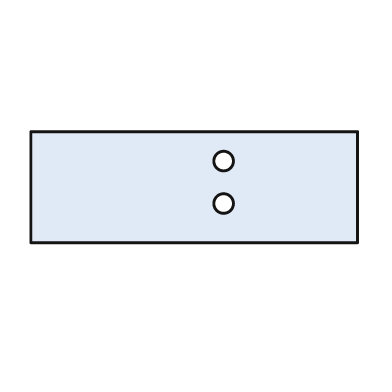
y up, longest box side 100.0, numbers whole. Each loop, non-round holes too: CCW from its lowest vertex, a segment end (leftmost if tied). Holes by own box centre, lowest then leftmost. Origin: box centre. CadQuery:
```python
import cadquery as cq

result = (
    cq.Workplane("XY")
    .moveTo(-50.0, -17.0)
    .lineTo(50.0, -17.0)
    .lineTo(50.0, 17.0)
    .lineTo(-50.0, 17.0)
    .close()
    .moveTo(9.0, -5.0)
    .circle(3.0)
    .moveTo(9.0, 8.0)
    .circle(3.0)
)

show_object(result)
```